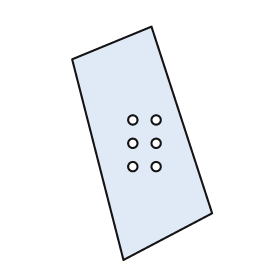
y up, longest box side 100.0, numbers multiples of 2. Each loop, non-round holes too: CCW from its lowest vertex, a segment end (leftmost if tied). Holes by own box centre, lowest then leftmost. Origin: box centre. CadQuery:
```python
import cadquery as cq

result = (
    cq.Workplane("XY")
    .moveTo(-8.0, -50.0)
    .lineTo(30.0, -30.0)
    .lineTo(4.0, 50.0)
    .lineTo(-30.0, 36.0)
    .close()
    .moveTo(-4.0, -10.0)
    .circle(2.0)
    .moveTo(6.0, -10.0)
    .circle(2.0)
    .moveTo(-4.0, 0.0)
    .circle(2.0)
    .moveTo(6.0, 0.0)
    .circle(2.0)
    .moveTo(-4.0, 10.0)
    .circle(2.0)
    .moveTo(6.0, 10.0)
    .circle(2.0)
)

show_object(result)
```